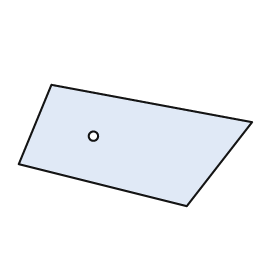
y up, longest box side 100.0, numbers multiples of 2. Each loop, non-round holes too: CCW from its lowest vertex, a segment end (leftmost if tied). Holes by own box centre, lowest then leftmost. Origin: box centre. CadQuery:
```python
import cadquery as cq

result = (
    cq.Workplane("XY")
    .moveTo(22.0, -26.0)
    .lineTo(50.0, 10.0)
    .lineTo(-36.0, 26.0)
    .lineTo(-50.0, -8.0)
    .close()
    .moveTo(-18.0, 4.0)
    .circle(2.0)
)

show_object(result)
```